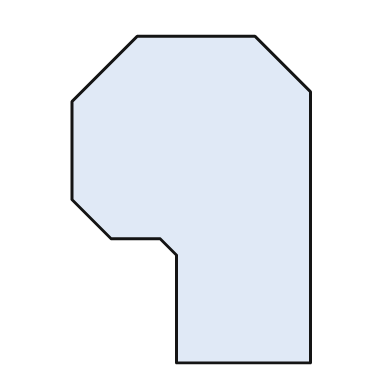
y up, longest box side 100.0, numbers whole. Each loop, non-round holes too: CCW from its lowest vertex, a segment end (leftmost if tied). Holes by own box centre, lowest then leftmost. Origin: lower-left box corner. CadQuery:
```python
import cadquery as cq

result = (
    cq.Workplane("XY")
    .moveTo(32.0, 0.0)
    .lineTo(73.0, 0.0)
    .lineTo(73.0, 83.0)
    .lineTo(56.0, 100.0)
    .lineTo(20.0, 100.0)
    .lineTo(0.0, 80.0)
    .lineTo(0.0, 50.0)
    .lineTo(12.0, 38.0)
    .lineTo(27.0, 38.0)
    .lineTo(32.0, 33.0)
    .close()
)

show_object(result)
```